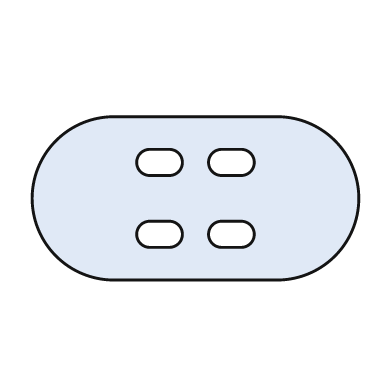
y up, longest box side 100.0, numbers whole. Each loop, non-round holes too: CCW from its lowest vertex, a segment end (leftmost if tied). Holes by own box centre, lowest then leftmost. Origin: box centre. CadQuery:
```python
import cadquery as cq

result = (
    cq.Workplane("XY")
    .moveTo(-25.0, -25.0)
    .lineTo(25.0, -25.0)
    .threePointArc((50.0, 0.0), (25.0, 25.0))
    .lineTo(-25.0, 25.0)
    .threePointArc((-50.0, 0.0), (-25.0, -25.0))
    .close()
    .moveTo(-14.0, -15.0)
    .lineTo(-8.0, -15.0)
    .threePointArc((-4.0, -11.0), (-8.0, -7.0))
    .lineTo(-14.0, -7.0)
    .threePointArc((-18.0, -11.0), (-14.0, -15.0))
    .close()
    .moveTo(8.0, -15.0)
    .lineTo(14.0, -15.0)
    .threePointArc((18.0, -11.0), (14.0, -7.0))
    .lineTo(8.0, -7.0)
    .threePointArc((4.0, -11.0), (8.0, -15.0))
    .close()
    .moveTo(-14.0, 7.0)
    .lineTo(-8.0, 7.0)
    .threePointArc((-4.0, 11.0), (-8.0, 15.0))
    .lineTo(-14.0, 15.0)
    .threePointArc((-18.0, 11.0), (-14.0, 7.0))
    .close()
    .moveTo(8.0, 7.0)
    .lineTo(14.0, 7.0)
    .threePointArc((18.0, 11.0), (14.0, 15.0))
    .lineTo(8.0, 15.0)
    .threePointArc((4.0, 11.0), (8.0, 7.0))
    .close()
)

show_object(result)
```